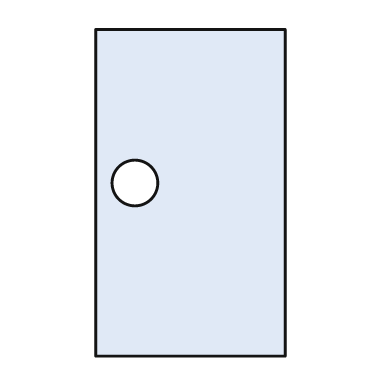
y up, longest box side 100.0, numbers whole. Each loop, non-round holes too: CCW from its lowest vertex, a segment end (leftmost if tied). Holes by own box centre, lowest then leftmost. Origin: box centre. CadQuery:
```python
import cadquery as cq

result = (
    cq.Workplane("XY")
    .moveTo(-29.0, -50.0)
    .lineTo(29.0, -50.0)
    .lineTo(29.0, 50.0)
    .lineTo(-29.0, 50.0)
    .close()
    .moveTo(-17.0, 3.0)
    .circle(7.0)
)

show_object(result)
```